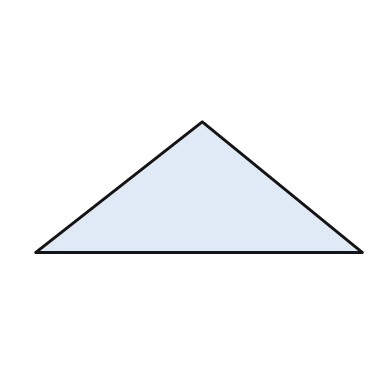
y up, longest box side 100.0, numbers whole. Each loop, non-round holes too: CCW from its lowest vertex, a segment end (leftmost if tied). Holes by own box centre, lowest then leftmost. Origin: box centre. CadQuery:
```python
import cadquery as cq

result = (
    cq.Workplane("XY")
    .moveTo(-50.0, -20.0)
    .lineTo(50.0, -20.0)
    .lineTo(1.0, 20.0)
    .close()
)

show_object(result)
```